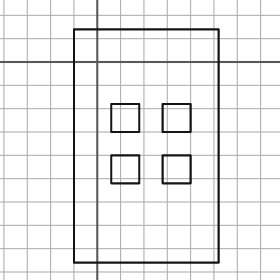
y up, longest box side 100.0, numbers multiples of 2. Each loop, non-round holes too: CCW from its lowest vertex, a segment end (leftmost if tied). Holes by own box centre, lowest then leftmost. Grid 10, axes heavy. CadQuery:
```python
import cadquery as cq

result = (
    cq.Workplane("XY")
    .moveTo(-10.0, -86.0)
    .lineTo(52.0, -86.0)
    .lineTo(52.0, 14.0)
    .lineTo(-10.0, 14.0)
    .close()
    .moveTo(6.0, -52.0)
    .lineTo(18.0, -52.0)
    .lineTo(18.0, -40.0)
    .lineTo(6.0, -40.0)
    .close()
    .moveTo(28.0, -52.0)
    .lineTo(40.0, -52.0)
    .lineTo(40.0, -40.0)
    .lineTo(28.0, -40.0)
    .close()
    .moveTo(6.0, -30.0)
    .lineTo(18.0, -30.0)
    .lineTo(18.0, -18.0)
    .lineTo(6.0, -18.0)
    .close()
    .moveTo(28.0, -30.0)
    .lineTo(40.0, -30.0)
    .lineTo(40.0, -18.0)
    .lineTo(28.0, -18.0)
    .close()
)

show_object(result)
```